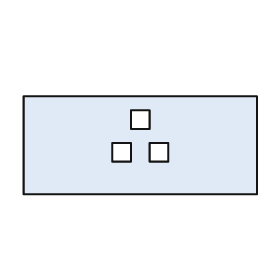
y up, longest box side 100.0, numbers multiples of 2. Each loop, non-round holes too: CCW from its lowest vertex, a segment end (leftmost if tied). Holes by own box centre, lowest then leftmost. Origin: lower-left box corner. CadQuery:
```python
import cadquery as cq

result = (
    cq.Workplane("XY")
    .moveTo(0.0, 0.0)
    .lineTo(100.0, 0.0)
    .lineTo(100.0, 42.0)
    .lineTo(0.0, 42.0)
    .close()
    .moveTo(38.0, 14.0)
    .lineTo(46.0, 14.0)
    .lineTo(46.0, 22.0)
    .lineTo(38.0, 22.0)
    .close()
    .moveTo(54.0, 14.0)
    .lineTo(62.0, 14.0)
    .lineTo(62.0, 22.0)
    .lineTo(54.0, 22.0)
    .close()
    .moveTo(46.0, 28.0)
    .lineTo(54.0, 28.0)
    .lineTo(54.0, 36.0)
    .lineTo(46.0, 36.0)
    .close()
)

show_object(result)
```